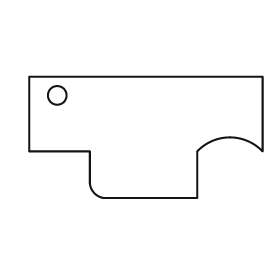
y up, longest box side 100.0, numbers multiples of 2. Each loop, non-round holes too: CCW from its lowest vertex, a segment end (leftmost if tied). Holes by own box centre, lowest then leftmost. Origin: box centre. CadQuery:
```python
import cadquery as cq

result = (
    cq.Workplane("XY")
    .moveTo(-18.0, -26.0)
    .lineTo(22.0, -26.0)
    .lineTo(22.0, -6.0)
    .threePointArc((36.0, 0.0), (50.0, -6.0))
    .lineTo(50.0, 26.0)
    .lineTo(-50.0, 26.0)
    .lineTo(-50.0, -6.0)
    .lineTo(-24.0, -6.0)
    .lineTo(-24.0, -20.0)
    .threePointArc((-22.0, -24.0), (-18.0, -26.0))
    .close()
    .moveTo(-38.0, 18.0)
    .circle(4.0)
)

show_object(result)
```